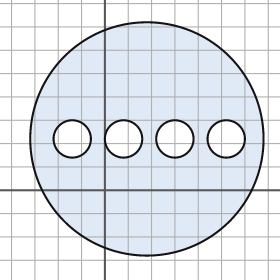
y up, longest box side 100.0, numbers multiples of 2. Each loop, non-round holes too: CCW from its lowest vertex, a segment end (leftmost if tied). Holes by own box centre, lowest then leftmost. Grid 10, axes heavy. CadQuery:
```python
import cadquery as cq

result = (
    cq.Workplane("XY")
    .moveTo(18.0, 22.0)
    .circle(50.0)
    .moveTo(-14.0, 22.0)
    .circle(8.0)
    .moveTo(8.0, 22.0)
    .circle(8.0)
    .moveTo(30.0, 22.0)
    .circle(8.0)
    .moveTo(52.0, 22.0)
    .circle(8.0)
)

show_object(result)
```